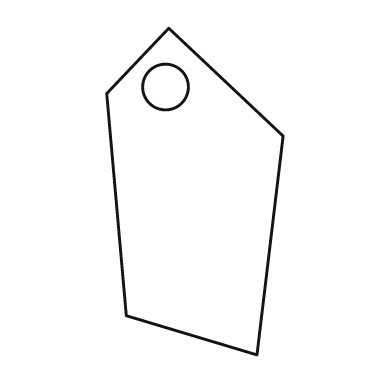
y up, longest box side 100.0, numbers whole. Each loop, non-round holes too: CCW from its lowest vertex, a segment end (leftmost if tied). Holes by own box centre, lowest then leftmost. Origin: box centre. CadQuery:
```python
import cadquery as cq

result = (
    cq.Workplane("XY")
    .moveTo(19.0, -50.0)
    .lineTo(27.0, 17.0)
    .lineTo(-8.0, 50.0)
    .lineTo(-27.0, 30.0)
    .lineTo(-21.0, -38.0)
    .close()
    .moveTo(-9.0, 32.0)
    .circle(7.0)
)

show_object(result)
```